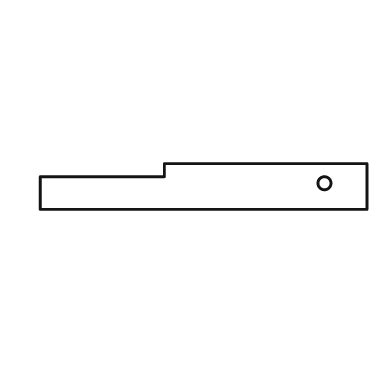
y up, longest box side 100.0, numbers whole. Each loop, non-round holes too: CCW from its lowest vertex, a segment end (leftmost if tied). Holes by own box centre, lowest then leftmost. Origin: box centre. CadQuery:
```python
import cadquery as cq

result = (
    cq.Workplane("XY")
    .moveTo(-50.0, -7.0)
    .lineTo(50.0, -7.0)
    .lineTo(50.0, 7.0)
    .lineTo(-12.0, 7.0)
    .lineTo(-12.0, 3.0)
    .lineTo(-50.0, 3.0)
    .close()
    .moveTo(37.0, 1.0)
    .circle(2.0)
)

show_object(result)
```